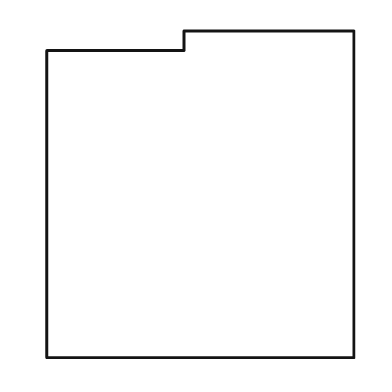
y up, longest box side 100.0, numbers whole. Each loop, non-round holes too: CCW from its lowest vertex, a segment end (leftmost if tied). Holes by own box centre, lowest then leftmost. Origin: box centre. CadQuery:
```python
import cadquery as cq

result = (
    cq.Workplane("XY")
    .moveTo(-47.0, -50.0)
    .lineTo(47.0, -50.0)
    .lineTo(47.0, 50.0)
    .lineTo(-5.0, 50.0)
    .lineTo(-5.0, 44.0)
    .lineTo(-47.0, 44.0)
    .close()
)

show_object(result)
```